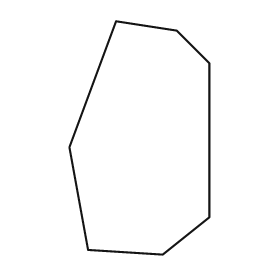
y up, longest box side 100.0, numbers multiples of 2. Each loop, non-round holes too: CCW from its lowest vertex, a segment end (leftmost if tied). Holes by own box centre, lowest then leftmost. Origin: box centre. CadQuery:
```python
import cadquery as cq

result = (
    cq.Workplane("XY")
    .moveTo(10.0, -50.0)
    .lineTo(30.0, -34.0)
    .lineTo(30.0, 32.0)
    .lineTo(16.0, 46.0)
    .lineTo(-10.0, 50.0)
    .lineTo(-30.0, -4.0)
    .lineTo(-22.0, -48.0)
    .close()
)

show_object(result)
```